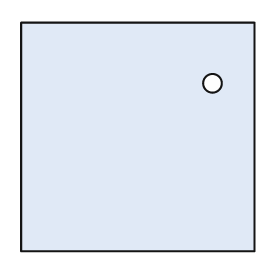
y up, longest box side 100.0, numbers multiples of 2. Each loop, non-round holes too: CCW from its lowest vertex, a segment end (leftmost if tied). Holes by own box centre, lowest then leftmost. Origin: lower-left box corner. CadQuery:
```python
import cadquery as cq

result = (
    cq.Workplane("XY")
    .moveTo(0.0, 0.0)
    .lineTo(100.0, 0.0)
    .lineTo(100.0, 98.0)
    .lineTo(0.0, 98.0)
    .close()
    .moveTo(82.0, 72.0)
    .circle(4.0)
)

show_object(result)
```